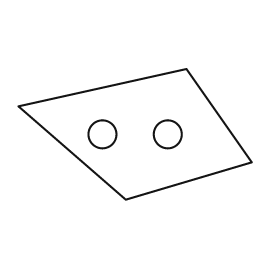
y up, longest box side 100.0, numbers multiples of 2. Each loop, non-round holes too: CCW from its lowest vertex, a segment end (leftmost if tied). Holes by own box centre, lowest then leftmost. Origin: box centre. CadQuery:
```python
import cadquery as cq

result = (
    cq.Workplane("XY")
    .moveTo(-4.0, -28.0)
    .lineTo(50.0, -12.0)
    .lineTo(22.0, 28.0)
    .lineTo(-50.0, 12.0)
    .close()
    .moveTo(-14.0, 0.0)
    .circle(6.0)
    .moveTo(14.0, 0.0)
    .circle(6.0)
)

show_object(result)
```